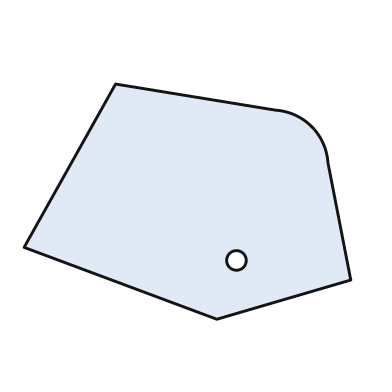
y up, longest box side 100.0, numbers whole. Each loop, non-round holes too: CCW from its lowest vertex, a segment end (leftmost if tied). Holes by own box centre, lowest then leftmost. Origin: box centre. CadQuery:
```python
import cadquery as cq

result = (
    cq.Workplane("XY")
    .moveTo(9.0, -36.0)
    .lineTo(50.0, -24.0)
    .lineTo(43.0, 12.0)
    .threePointArc((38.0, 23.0), (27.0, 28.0))
    .lineTo(-22.0, 36.0)
    .lineTo(-50.0, -14.0)
    .close()
    .moveTo(15.0, -18.0)
    .circle(3.0)
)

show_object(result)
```